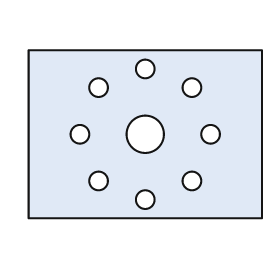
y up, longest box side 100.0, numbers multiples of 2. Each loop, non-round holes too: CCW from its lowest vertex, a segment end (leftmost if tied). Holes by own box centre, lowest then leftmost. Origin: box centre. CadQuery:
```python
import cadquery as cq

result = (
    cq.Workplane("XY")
    .moveTo(-50.0, -36.0)
    .lineTo(50.0, -36.0)
    .lineTo(50.0, 36.0)
    .lineTo(-50.0, 36.0)
    .close()
    .moveTo(0.0, -28.0)
    .circle(4.0)
    .moveTo(-20.0, -20.0)
    .circle(4.0)
    .moveTo(20.0, -20.0)
    .circle(4.0)
    .moveTo(-28.0, 0.0)
    .circle(4.0)
    .moveTo(0.0, 0.0)
    .circle(8.0)
    .moveTo(28.0, 0.0)
    .circle(4.0)
    .moveTo(-20.0, 20.0)
    .circle(4.0)
    .moveTo(20.0, 20.0)
    .circle(4.0)
    .moveTo(0.0, 28.0)
    .circle(4.0)
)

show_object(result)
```